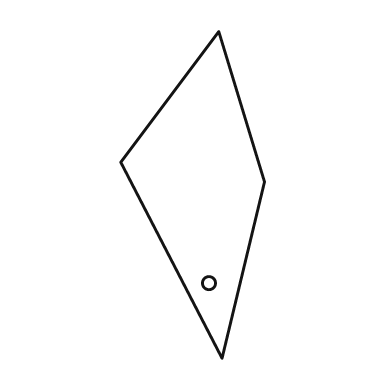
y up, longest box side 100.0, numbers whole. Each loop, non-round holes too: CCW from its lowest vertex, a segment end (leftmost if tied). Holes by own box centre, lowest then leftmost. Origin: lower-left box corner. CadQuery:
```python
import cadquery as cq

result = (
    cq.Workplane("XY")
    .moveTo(31.0, 0.0)
    .lineTo(44.0, 54.0)
    .lineTo(30.0, 100.0)
    .lineTo(0.0, 60.0)
    .close()
    .moveTo(27.0, 23.0)
    .circle(2.0)
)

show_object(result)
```